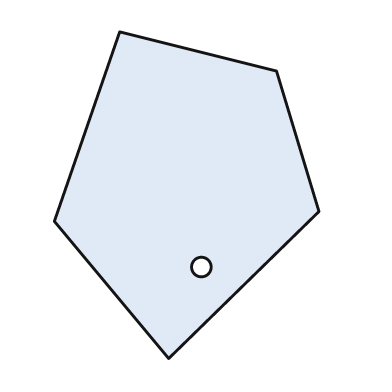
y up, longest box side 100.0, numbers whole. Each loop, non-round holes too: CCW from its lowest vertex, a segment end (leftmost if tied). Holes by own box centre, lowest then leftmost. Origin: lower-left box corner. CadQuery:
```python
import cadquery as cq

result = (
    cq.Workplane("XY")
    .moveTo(35.0, 0.0)
    .lineTo(81.0, 45.0)
    .lineTo(68.0, 88.0)
    .lineTo(20.0, 100.0)
    .lineTo(0.0, 42.0)
    .close()
    .moveTo(45.0, 28.0)
    .circle(3.0)
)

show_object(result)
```